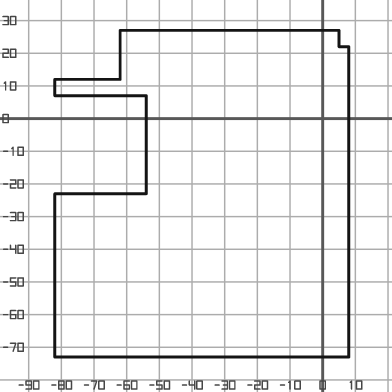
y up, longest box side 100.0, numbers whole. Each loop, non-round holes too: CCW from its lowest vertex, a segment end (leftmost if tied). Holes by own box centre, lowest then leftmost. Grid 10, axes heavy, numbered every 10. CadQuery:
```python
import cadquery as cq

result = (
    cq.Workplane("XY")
    .moveTo(-82.0, -73.0)
    .lineTo(8.0, -73.0)
    .lineTo(8.0, 22.0)
    .lineTo(5.0, 22.0)
    .lineTo(5.0, 27.0)
    .lineTo(-62.0, 27.0)
    .lineTo(-62.0, 12.0)
    .lineTo(-82.0, 12.0)
    .lineTo(-82.0, 7.0)
    .lineTo(-54.0, 7.0)
    .lineTo(-54.0, -23.0)
    .lineTo(-82.0, -23.0)
    .close()
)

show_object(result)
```